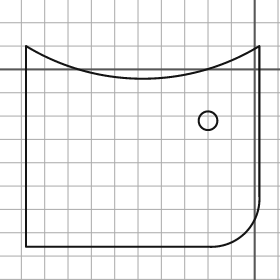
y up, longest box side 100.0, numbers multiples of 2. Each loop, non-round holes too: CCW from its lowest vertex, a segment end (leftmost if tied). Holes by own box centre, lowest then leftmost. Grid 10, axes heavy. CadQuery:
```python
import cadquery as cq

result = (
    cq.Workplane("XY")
    .moveTo(-98.0, -76.0)
    .lineTo(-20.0, -76.0)
    .threePointArc((-4.0, -70.0), (2.0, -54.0))
    .lineTo(2.0, 10.0)
    .threePointArc((-48.0, -4.0), (-98.0, 10.0))
    .close()
    .moveTo(-20.0, -22.0)
    .circle(4.0)
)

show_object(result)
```